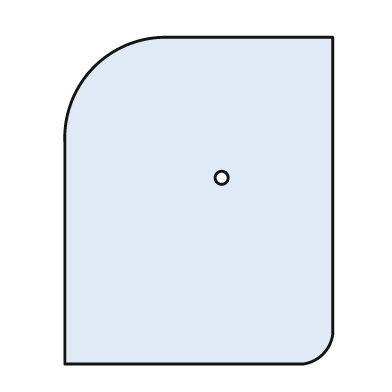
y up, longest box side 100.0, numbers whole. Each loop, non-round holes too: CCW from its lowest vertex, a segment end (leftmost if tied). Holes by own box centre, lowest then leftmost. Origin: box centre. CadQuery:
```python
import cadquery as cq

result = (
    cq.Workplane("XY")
    .moveTo(-41.0, -50.0)
    .lineTo(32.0, -50.0)
    .threePointArc((38.0, -47.0), (41.0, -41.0))
    .lineTo(41.0, 50.0)
    .lineTo(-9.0, 50.0)
    .threePointArc((-32.0, 41.0), (-41.0, 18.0))
    .close()
    .moveTo(7.0, 7.0)
    .circle(2.0)
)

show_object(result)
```